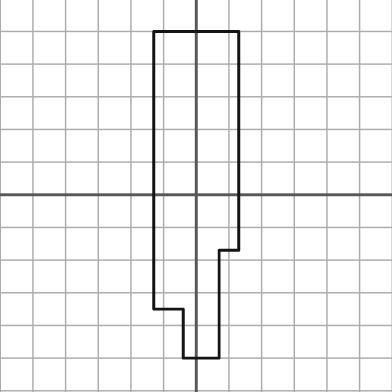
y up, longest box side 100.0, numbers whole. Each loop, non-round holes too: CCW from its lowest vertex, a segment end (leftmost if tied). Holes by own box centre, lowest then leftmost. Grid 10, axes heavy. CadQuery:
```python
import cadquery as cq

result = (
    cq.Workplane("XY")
    .moveTo(-4.0, -50.0)
    .lineTo(7.0, -50.0)
    .lineTo(7.0, -17.0)
    .lineTo(13.0, -17.0)
    .lineTo(13.0, 50.0)
    .lineTo(-13.0, 50.0)
    .lineTo(-13.0, -35.0)
    .lineTo(-4.0, -35.0)
    .close()
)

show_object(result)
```